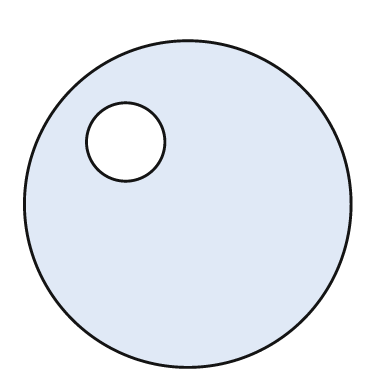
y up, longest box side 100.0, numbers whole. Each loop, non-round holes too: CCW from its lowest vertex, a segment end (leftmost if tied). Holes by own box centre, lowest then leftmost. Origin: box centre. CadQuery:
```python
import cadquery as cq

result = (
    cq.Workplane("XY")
    .moveTo(0.0, 0.0)
    .circle(50.0)
    .moveTo(-19.0, 19.0)
    .circle(12.0)
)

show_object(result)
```